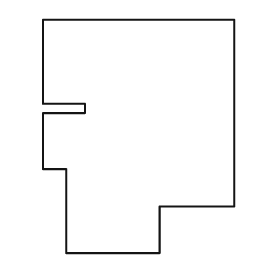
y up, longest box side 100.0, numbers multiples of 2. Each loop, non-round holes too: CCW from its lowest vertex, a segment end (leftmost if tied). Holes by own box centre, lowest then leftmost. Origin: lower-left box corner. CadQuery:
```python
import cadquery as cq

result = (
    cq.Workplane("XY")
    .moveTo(10.0, 0.0)
    .lineTo(50.0, 0.0)
    .lineTo(50.0, 20.0)
    .lineTo(82.0, 20.0)
    .lineTo(82.0, 100.0)
    .lineTo(0.0, 100.0)
    .lineTo(0.0, 64.0)
    .lineTo(18.0, 64.0)
    .lineTo(18.0, 60.0)
    .lineTo(0.0, 60.0)
    .lineTo(0.0, 36.0)
    .lineTo(10.0, 36.0)
    .close()
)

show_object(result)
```